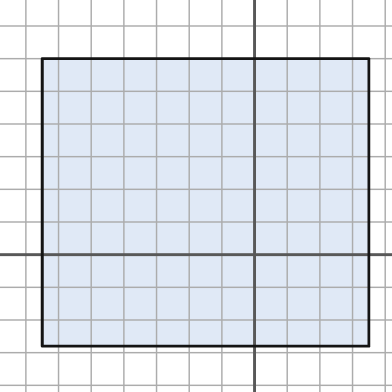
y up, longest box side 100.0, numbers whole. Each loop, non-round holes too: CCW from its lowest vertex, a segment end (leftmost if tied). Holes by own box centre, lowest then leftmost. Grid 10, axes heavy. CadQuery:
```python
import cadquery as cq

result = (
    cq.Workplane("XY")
    .moveTo(-65.0, -28.0)
    .lineTo(35.0, -28.0)
    .lineTo(35.0, 60.0)
    .lineTo(-65.0, 60.0)
    .close()
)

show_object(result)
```